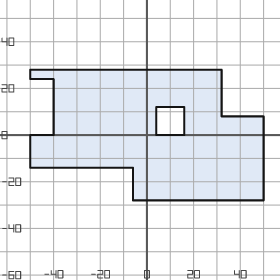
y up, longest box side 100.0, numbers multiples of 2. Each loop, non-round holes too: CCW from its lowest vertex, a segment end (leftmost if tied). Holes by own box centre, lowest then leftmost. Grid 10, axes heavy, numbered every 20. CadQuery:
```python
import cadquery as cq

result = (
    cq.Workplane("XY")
    .moveTo(-6.0, -28.0)
    .lineTo(50.0, -28.0)
    .lineTo(50.0, 8.0)
    .lineTo(32.0, 8.0)
    .lineTo(32.0, 28.0)
    .lineTo(-50.0, 28.0)
    .lineTo(-50.0, 24.0)
    .lineTo(-40.0, 24.0)
    .lineTo(-40.0, 0.0)
    .lineTo(-50.0, 0.0)
    .lineTo(-50.0, -14.0)
    .lineTo(-6.0, -14.0)
    .close()
    .moveTo(4.0, 0.0)
    .lineTo(16.0, 0.0)
    .lineTo(16.0, 12.0)
    .lineTo(4.0, 12.0)
    .close()
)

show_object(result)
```